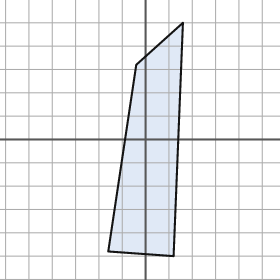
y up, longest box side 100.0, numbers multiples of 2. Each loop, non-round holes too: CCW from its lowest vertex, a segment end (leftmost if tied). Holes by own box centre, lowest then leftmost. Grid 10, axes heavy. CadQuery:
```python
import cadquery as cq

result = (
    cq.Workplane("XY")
    .moveTo(12.0, -50.0)
    .lineTo(16.0, 50.0)
    .lineTo(-4.0, 32.0)
    .lineTo(-16.0, -48.0)
    .close()
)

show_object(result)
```